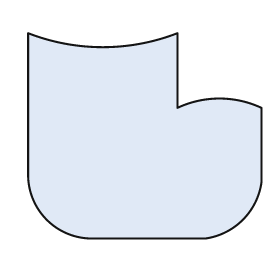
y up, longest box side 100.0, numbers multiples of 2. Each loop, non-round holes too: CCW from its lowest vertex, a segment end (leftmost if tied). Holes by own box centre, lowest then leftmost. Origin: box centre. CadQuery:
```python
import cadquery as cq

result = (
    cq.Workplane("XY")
    .moveTo(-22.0, -44.0)
    .lineTo(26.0, -44.0)
    .threePointArc((42.0, -36.0), (50.0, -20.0))
    .lineTo(50.0, 12.0)
    .threePointArc((32.0, 16.0), (14.0, 12.0))
    .lineTo(14.0, 44.0)
    .threePointArc((-18.0, 38.0), (-50.0, 44.0))
    .lineTo(-50.0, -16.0)
    .threePointArc((-42.0, -36.0), (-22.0, -44.0))
    .close()
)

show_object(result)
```